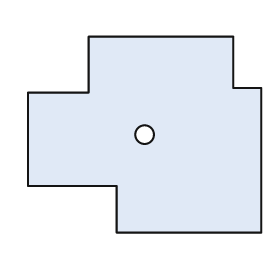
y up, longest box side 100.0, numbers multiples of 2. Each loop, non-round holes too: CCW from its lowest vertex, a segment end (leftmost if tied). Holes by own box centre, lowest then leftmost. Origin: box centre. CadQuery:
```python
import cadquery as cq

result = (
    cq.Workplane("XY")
    .moveTo(-12.0, -42.0)
    .lineTo(50.0, -42.0)
    .lineTo(50.0, 20.0)
    .lineTo(38.0, 20.0)
    .lineTo(38.0, 42.0)
    .lineTo(-24.0, 42.0)
    .lineTo(-24.0, 18.0)
    .lineTo(-50.0, 18.0)
    .lineTo(-50.0, -22.0)
    .lineTo(-12.0, -22.0)
    .close()
    .moveTo(0.0, 0.0)
    .circle(4.0)
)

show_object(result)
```